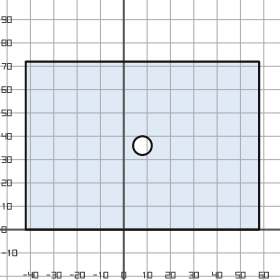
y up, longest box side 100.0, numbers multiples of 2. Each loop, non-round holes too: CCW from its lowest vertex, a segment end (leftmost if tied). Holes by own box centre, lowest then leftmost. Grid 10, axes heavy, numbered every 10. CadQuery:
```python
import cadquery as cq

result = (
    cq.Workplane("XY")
    .moveTo(-42.0, 0.0)
    .lineTo(58.0, 0.0)
    .lineTo(58.0, 72.0)
    .lineTo(-42.0, 72.0)
    .close()
    .moveTo(8.0, 36.0)
    .circle(4.0)
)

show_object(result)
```